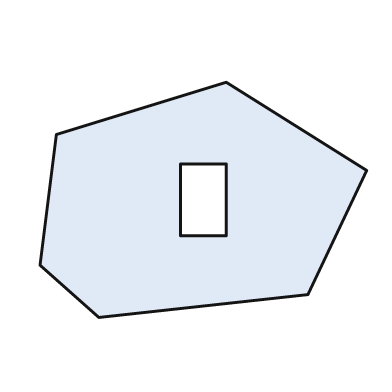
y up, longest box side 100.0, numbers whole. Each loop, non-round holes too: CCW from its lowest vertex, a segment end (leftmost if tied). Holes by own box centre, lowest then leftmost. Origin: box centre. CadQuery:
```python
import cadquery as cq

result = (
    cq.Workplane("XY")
    .moveTo(-32.0, -36.0)
    .lineTo(32.0, -29.0)
    .lineTo(50.0, 9.0)
    .lineTo(7.0, 36.0)
    .lineTo(-45.0, 20.0)
    .lineTo(-50.0, -20.0)
    .close()
    .moveTo(-7.0, -11.0)
    .lineTo(7.0, -11.0)
    .lineTo(7.0, 11.0)
    .lineTo(-7.0, 11.0)
    .close()
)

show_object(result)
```